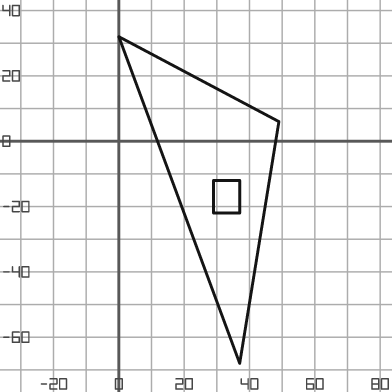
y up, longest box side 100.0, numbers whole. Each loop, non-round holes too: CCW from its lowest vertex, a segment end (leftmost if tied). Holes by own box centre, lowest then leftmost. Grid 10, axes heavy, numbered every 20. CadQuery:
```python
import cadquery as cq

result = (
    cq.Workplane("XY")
    .moveTo(37.0, -68.0)
    .lineTo(49.0, 6.0)
    .lineTo(0.0, 32.0)
    .close()
    .moveTo(29.0, -22.0)
    .lineTo(37.0, -22.0)
    .lineTo(37.0, -12.0)
    .lineTo(29.0, -12.0)
    .close()
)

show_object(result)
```